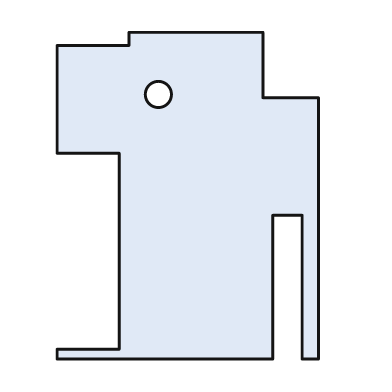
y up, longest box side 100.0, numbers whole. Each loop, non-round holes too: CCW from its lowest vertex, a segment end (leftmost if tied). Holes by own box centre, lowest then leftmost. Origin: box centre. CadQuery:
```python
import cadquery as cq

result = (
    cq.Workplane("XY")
    .moveTo(-40.0, -50.0)
    .lineTo(26.0, -50.0)
    .lineTo(26.0, -6.0)
    .lineTo(35.0, -6.0)
    .lineTo(35.0, -50.0)
    .lineTo(40.0, -50.0)
    .lineTo(40.0, 30.0)
    .lineTo(23.0, 30.0)
    .lineTo(23.0, 50.0)
    .lineTo(-18.0, 50.0)
    .lineTo(-18.0, 46.0)
    .lineTo(-40.0, 46.0)
    .lineTo(-40.0, 13.0)
    .lineTo(-21.0, 13.0)
    .lineTo(-21.0, -47.0)
    .lineTo(-40.0, -47.0)
    .close()
    .moveTo(-9.0, 31.0)
    .circle(4.0)
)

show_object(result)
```